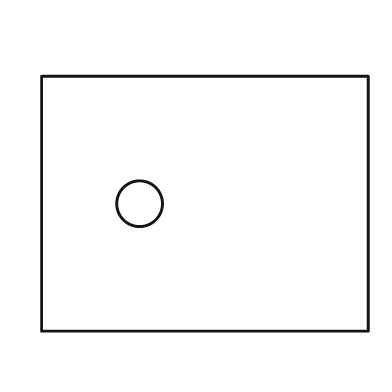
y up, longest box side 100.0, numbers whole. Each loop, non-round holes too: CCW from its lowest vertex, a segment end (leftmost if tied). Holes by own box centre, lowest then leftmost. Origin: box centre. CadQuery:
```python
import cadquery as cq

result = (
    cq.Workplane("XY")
    .moveTo(-50.0, -39.0)
    .lineTo(50.0, -39.0)
    .lineTo(50.0, 39.0)
    .lineTo(-50.0, 39.0)
    .close()
    .moveTo(-20.0, 0.0)
    .circle(7.0)
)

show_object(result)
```